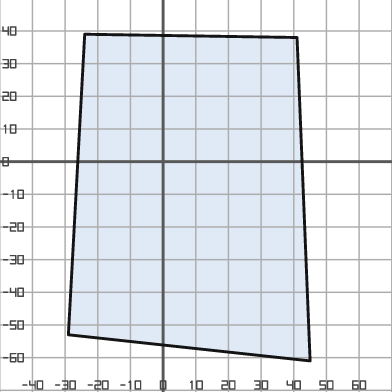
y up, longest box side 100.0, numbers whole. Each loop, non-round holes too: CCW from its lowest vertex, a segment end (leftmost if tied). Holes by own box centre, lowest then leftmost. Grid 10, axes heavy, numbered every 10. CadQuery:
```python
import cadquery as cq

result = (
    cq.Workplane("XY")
    .moveTo(45.0, -61.0)
    .lineTo(41.0, 38.0)
    .lineTo(-24.0, 39.0)
    .lineTo(-29.0, -53.0)
    .close()
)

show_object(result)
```